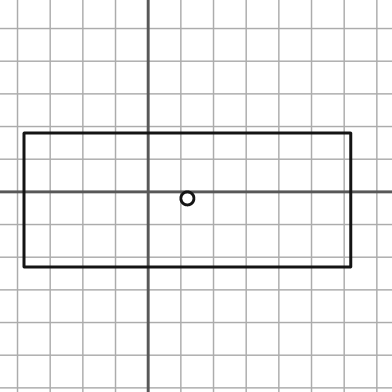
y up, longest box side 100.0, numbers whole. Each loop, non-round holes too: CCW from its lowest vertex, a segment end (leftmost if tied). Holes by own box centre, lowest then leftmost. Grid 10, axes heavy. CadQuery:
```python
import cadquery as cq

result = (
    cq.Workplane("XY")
    .moveTo(-38.0, -23.0)
    .lineTo(62.0, -23.0)
    .lineTo(62.0, 18.0)
    .lineTo(-38.0, 18.0)
    .close()
    .moveTo(12.0, -2.0)
    .circle(2.0)
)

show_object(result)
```